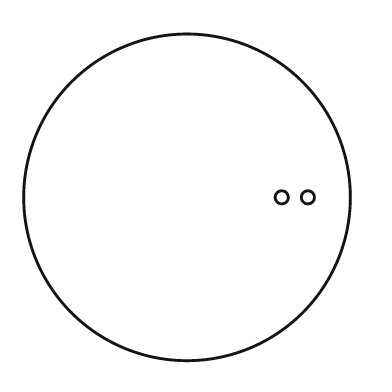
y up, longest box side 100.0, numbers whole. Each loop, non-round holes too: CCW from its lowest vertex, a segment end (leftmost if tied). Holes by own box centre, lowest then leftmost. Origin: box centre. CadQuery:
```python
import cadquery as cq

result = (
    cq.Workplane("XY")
    .moveTo(0.0, 0.0)
    .circle(50.0)
    .moveTo(29.0, 0.0)
    .circle(2.0)
    .moveTo(37.0, 0.0)
    .circle(2.0)
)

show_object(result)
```